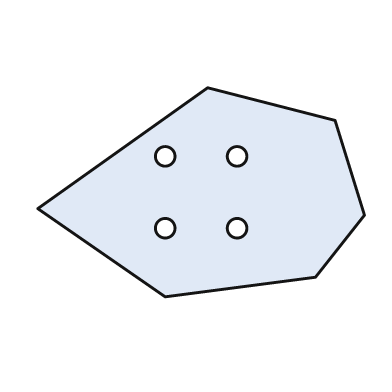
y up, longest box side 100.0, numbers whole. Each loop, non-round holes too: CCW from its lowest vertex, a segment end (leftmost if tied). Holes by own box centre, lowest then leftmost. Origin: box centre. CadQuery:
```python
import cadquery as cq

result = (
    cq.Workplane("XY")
    .moveTo(-11.0, -32.0)
    .lineTo(35.0, -26.0)
    .lineTo(50.0, -7.0)
    .lineTo(41.0, 22.0)
    .lineTo(2.0, 32.0)
    .lineTo(-50.0, -5.0)
    .close()
    .moveTo(-11.0, -11.0)
    .circle(3.0)
    .moveTo(11.0, -11.0)
    .circle(3.0)
    .moveTo(-11.0, 11.0)
    .circle(3.0)
    .moveTo(11.0, 11.0)
    .circle(3.0)
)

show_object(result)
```